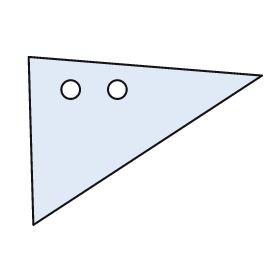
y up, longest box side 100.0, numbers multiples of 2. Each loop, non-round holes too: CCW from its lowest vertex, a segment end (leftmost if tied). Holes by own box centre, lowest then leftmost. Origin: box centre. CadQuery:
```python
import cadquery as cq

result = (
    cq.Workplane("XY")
    .moveTo(-48.0, -36.0)
    .lineTo(50.0, 28.0)
    .lineTo(-50.0, 36.0)
    .close()
    .moveTo(-32.0, 22.0)
    .circle(4.0)
    .moveTo(-12.0, 22.0)
    .circle(4.0)
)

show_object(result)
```